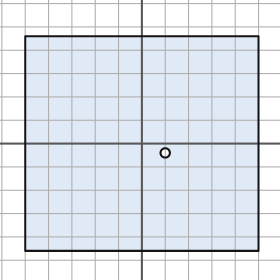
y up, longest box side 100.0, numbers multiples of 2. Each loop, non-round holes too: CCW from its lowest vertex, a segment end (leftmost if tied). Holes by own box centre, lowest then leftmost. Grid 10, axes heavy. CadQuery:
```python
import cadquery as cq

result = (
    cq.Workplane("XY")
    .moveTo(-50.0, -46.0)
    .lineTo(50.0, -46.0)
    .lineTo(50.0, 46.0)
    .lineTo(-50.0, 46.0)
    .close()
    .moveTo(10.0, -4.0)
    .circle(2.0)
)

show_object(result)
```